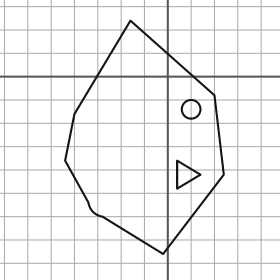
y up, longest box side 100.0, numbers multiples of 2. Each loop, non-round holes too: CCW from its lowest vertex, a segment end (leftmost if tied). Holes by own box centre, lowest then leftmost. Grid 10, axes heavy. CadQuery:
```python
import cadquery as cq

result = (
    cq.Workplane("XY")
    .moveTo(-2.0, -76.0)
    .lineTo(24.0, -42.0)
    .lineTo(20.0, -8.0)
    .lineTo(-16.0, 24.0)
    .lineTo(-40.0, -16.0)
    .lineTo(-44.0, -36.0)
    .lineTo(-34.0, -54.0)
    .threePointArc((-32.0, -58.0), (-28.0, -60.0))
    .close()
    .moveTo(4.0, -48.0)
    .lineTo(14.0, -42.0)
    .lineTo(4.0, -36.0)
    .close()
    .moveTo(10.0, -14.0)
    .circle(4.0)
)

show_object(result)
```